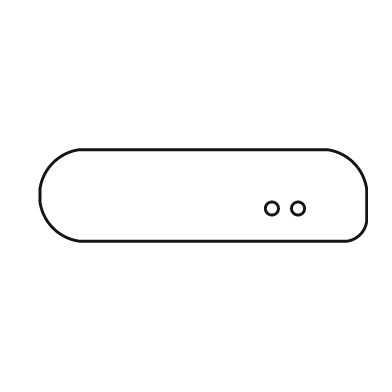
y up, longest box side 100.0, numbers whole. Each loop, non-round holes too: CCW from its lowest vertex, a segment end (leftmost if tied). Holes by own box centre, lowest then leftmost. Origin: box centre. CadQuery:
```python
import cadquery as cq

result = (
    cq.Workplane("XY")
    .moveTo(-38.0, -14.0)
    .lineTo(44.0, -14.0)
    .threePointArc((48.0, -12.0), (50.0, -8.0))
    .lineTo(50.0, 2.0)
    .threePointArc((46.0, 10.0), (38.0, 14.0))
    .lineTo(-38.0, 14.0)
    .threePointArc((-46.0, 10.0), (-50.0, 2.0))
    .lineTo(-50.0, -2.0)
    .threePointArc((-46.0, -10.0), (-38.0, -14.0))
    .close()
    .moveTo(21.0, -4.0)
    .circle(2.0)
    .moveTo(29.0, -4.0)
    .circle(2.0)
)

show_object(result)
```